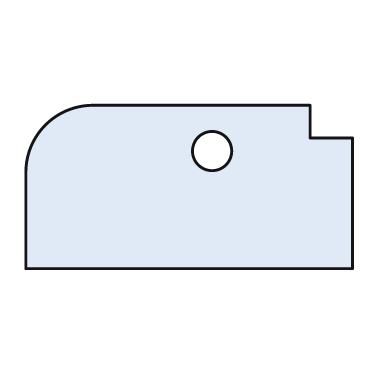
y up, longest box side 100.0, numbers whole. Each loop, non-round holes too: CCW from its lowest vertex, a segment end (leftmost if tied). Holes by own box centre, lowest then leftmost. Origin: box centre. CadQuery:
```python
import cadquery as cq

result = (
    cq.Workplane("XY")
    .moveTo(-50.0, -25.0)
    .lineTo(50.0, -25.0)
    .lineTo(50.0, 15.0)
    .lineTo(37.0, 15.0)
    .lineTo(37.0, 25.0)
    .lineTo(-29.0, 25.0)
    .threePointArc((-44.0, 19.0), (-50.0, 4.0))
    .close()
    .moveTo(7.0, 11.0)
    .circle(6.0)
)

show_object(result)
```